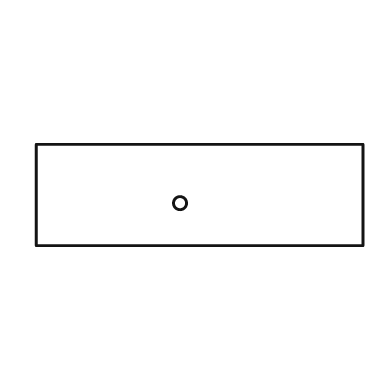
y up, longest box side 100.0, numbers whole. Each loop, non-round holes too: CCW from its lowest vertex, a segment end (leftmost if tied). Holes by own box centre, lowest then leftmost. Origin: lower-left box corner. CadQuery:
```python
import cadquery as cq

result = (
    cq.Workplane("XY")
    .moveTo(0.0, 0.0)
    .lineTo(100.0, 0.0)
    .lineTo(100.0, 31.0)
    .lineTo(0.0, 31.0)
    .close()
    .moveTo(44.0, 13.0)
    .circle(2.0)
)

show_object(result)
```